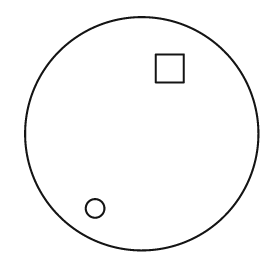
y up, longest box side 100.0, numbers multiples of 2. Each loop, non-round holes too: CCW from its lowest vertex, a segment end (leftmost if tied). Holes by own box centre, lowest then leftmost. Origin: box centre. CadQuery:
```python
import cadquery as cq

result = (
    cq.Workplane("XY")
    .moveTo(0.0, 0.0)
    .circle(50.0)
    .moveTo(-20.0, -32.0)
    .circle(4.0)
    .moveTo(6.0, 22.0)
    .lineTo(18.0, 22.0)
    .lineTo(18.0, 34.0)
    .lineTo(6.0, 34.0)
    .close()
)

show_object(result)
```